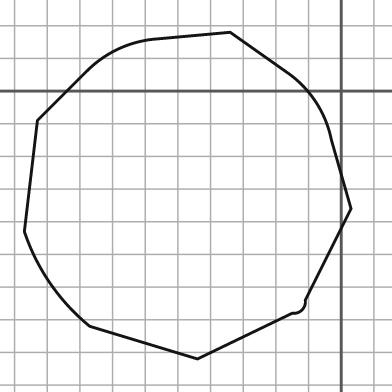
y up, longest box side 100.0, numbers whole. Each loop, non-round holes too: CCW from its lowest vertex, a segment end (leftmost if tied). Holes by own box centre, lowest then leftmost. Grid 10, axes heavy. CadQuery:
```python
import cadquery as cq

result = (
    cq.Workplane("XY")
    .moveTo(-44.0, -82.0)
    .lineTo(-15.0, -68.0)
    .threePointArc((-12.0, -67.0), (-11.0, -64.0))
    .lineTo(3.0, -36.0)
    .lineTo(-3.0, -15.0)
    .threePointArc((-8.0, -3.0), (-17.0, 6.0))
    .lineTo(-34.0, 18.0)
    .lineTo(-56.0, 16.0)
    .threePointArc((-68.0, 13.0), (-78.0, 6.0))
    .lineTo(-93.0, -9.0)
    .lineTo(-97.0, -43.0)
    .threePointArc((-89.0, -59.0), (-77.0, -72.0))
    .close()
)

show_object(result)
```